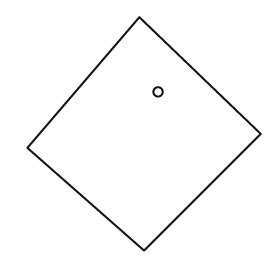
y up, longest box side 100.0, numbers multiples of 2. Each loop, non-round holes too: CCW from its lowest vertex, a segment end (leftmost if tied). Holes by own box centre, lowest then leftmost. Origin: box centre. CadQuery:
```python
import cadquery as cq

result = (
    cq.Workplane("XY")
    .moveTo(0.0, -50.0)
    .lineTo(50.0, 0.0)
    .lineTo(-2.0, 50.0)
    .lineTo(-50.0, -6.0)
    .close()
    .moveTo(6.0, 18.0)
    .circle(2.0)
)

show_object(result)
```